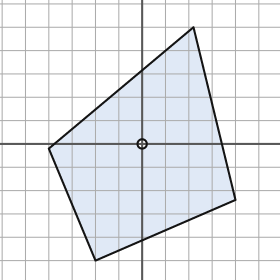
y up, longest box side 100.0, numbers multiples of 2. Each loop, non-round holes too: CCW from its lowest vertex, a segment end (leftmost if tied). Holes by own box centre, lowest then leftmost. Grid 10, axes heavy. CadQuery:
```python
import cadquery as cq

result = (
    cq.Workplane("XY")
    .moveTo(-20.0, -50.0)
    .lineTo(40.0, -24.0)
    .lineTo(22.0, 50.0)
    .lineTo(-40.0, -2.0)
    .close()
    .moveTo(0.0, 0.0)
    .circle(2.0)
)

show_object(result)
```